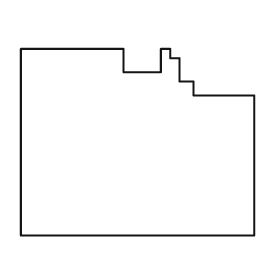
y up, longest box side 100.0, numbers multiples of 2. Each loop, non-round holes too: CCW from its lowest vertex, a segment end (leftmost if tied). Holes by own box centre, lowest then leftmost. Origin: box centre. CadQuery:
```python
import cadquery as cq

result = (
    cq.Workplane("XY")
    .moveTo(-50.0, -40.0)
    .lineTo(50.0, -40.0)
    .lineTo(50.0, 20.0)
    .lineTo(24.0, 20.0)
    .lineTo(24.0, 26.0)
    .lineTo(18.0, 26.0)
    .lineTo(18.0, 36.0)
    .lineTo(14.0, 36.0)
    .lineTo(14.0, 40.0)
    .lineTo(10.0, 40.0)
    .lineTo(10.0, 30.0)
    .lineTo(-6.0, 30.0)
    .lineTo(-6.0, 40.0)
    .lineTo(-50.0, 40.0)
    .close()
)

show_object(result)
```